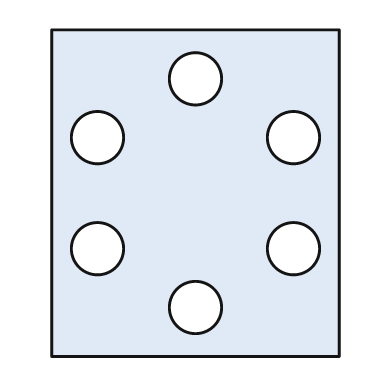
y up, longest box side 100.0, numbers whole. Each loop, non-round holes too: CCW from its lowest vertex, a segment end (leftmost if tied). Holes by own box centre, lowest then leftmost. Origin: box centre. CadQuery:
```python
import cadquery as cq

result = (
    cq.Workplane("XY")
    .moveTo(-44.0, -50.0)
    .lineTo(44.0, -50.0)
    .lineTo(44.0, 50.0)
    .lineTo(-44.0, 50.0)
    .close()
    .moveTo(0.0, -35.0)
    .circle(8.0)
    .moveTo(-30.0, -17.0)
    .circle(8.0)
    .moveTo(30.0, -17.0)
    .circle(8.0)
    .moveTo(-30.0, 17.0)
    .circle(8.0)
    .moveTo(30.0, 17.0)
    .circle(8.0)
    .moveTo(0.0, 35.0)
    .circle(8.0)
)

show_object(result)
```